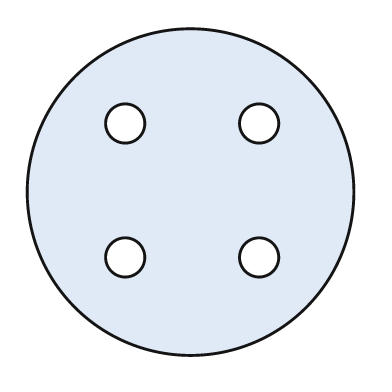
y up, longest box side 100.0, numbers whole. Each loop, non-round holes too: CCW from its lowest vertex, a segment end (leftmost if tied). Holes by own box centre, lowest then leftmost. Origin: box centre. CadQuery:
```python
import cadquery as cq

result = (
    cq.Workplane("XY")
    .moveTo(0.0, 0.0)
    .circle(50.0)
    .moveTo(-20.0, -20.0)
    .circle(6.0)
    .moveTo(21.0, -20.0)
    .circle(6.0)
    .moveTo(-20.0, 21.0)
    .circle(6.0)
    .moveTo(21.0, 21.0)
    .circle(6.0)
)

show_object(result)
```